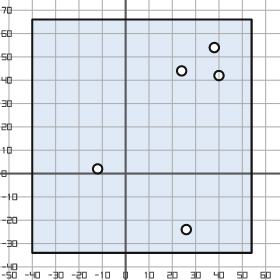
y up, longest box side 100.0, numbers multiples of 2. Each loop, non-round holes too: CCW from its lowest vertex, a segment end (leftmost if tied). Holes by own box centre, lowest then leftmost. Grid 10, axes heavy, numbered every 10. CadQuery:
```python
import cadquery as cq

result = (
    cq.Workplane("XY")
    .moveTo(-40.0, -34.0)
    .lineTo(54.0, -34.0)
    .lineTo(54.0, 66.0)
    .lineTo(-40.0, 66.0)
    .close()
    .moveTo(26.0, -24.0)
    .circle(2.0)
    .moveTo(-12.0, 2.0)
    .circle(2.0)
    .moveTo(40.0, 42.0)
    .circle(2.0)
    .moveTo(24.0, 44.0)
    .circle(2.0)
    .moveTo(38.0, 54.0)
    .circle(2.0)
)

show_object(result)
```